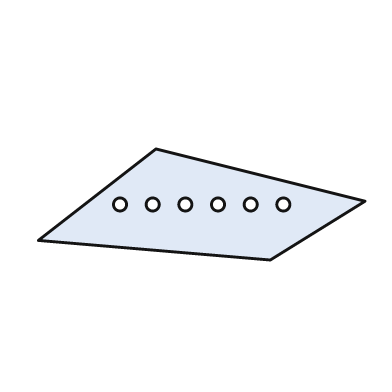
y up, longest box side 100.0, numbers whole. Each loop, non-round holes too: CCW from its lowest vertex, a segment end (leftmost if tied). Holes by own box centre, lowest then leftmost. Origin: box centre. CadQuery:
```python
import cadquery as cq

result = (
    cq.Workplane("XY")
    .moveTo(21.0, -17.0)
    .lineTo(50.0, 1.0)
    .lineTo(-14.0, 17.0)
    .lineTo(-50.0, -11.0)
    .close()
    .moveTo(-25.0, 0.0)
    .circle(2.0)
    .moveTo(-15.0, 0.0)
    .circle(2.0)
    .moveTo(-5.0, 0.0)
    .circle(2.0)
    .moveTo(5.0, 0.0)
    .circle(2.0)
    .moveTo(15.0, 0.0)
    .circle(2.0)
    .moveTo(25.0, 0.0)
    .circle(2.0)
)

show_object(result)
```